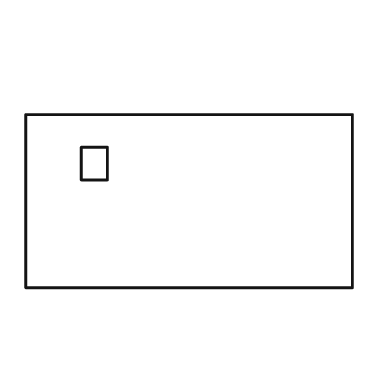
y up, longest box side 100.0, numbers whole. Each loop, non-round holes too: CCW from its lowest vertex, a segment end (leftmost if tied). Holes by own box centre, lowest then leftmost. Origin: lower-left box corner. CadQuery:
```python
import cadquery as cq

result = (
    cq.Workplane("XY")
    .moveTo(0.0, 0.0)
    .lineTo(100.0, 0.0)
    .lineTo(100.0, 53.0)
    .lineTo(0.0, 53.0)
    .close()
    .moveTo(17.0, 33.0)
    .lineTo(25.0, 33.0)
    .lineTo(25.0, 43.0)
    .lineTo(17.0, 43.0)
    .close()
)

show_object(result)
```